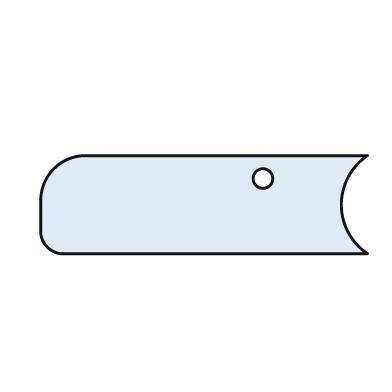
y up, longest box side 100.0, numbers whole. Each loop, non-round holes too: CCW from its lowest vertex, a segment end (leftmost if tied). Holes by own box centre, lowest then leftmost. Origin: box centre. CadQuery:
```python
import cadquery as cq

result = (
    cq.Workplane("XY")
    .moveTo(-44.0, -15.0)
    .lineTo(50.0, -15.0)
    .threePointArc((42.0, 0.0), (50.0, 15.0))
    .lineTo(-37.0, 15.0)
    .threePointArc((-46.0, 11.0), (-50.0, 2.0))
    .lineTo(-50.0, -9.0)
    .threePointArc((-48.0, -13.0), (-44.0, -15.0))
    .close()
    .moveTo(18.0, 8.0)
    .circle(3.0)
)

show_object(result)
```